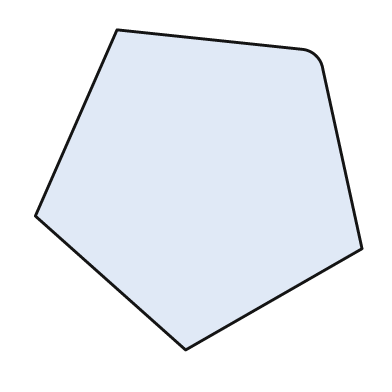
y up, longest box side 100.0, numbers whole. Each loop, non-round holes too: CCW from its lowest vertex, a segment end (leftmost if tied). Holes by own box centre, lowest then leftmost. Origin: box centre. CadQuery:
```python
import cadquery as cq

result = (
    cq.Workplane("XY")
    .moveTo(-4.0, -49.0)
    .lineTo(50.0, -18.0)
    .lineTo(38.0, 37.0)
    .threePointArc((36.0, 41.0), (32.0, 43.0))
    .lineTo(-25.0, 49.0)
    .lineTo(-50.0, -8.0)
    .close()
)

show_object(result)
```